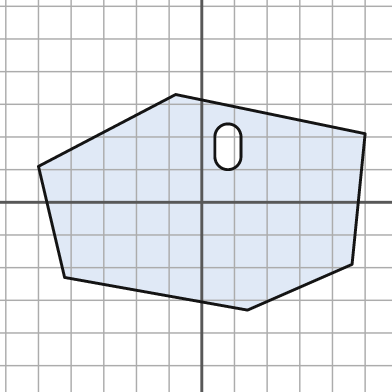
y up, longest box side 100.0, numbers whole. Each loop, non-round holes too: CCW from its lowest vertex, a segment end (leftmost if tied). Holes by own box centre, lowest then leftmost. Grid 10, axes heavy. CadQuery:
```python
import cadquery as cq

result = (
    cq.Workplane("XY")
    .moveTo(14.0, -33.0)
    .lineTo(46.0, -19.0)
    .lineTo(50.0, 21.0)
    .lineTo(-8.0, 33.0)
    .lineTo(-50.0, 11.0)
    .lineTo(-42.0, -23.0)
    .close()
    .moveTo(4.0, 14.0)
    .threePointArc((8.0, 10.0), (12.0, 14.0))
    .lineTo(12.0, 20.0)
    .threePointArc((8.0, 24.0), (4.0, 20.0))
    .close()
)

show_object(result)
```